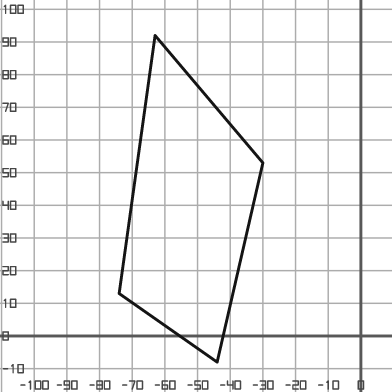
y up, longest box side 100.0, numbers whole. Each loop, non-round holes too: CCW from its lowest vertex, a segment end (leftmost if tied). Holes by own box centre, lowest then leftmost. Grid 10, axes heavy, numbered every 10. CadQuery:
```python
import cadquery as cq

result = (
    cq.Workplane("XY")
    .moveTo(-44.0, -8.0)
    .lineTo(-30.0, 53.0)
    .lineTo(-63.0, 92.0)
    .lineTo(-74.0, 13.0)
    .close()
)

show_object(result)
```